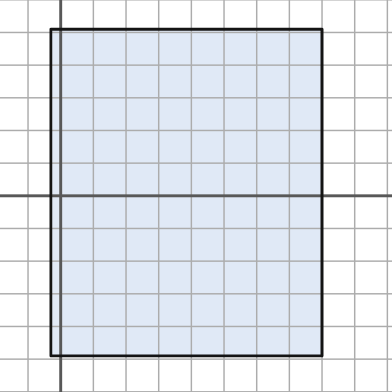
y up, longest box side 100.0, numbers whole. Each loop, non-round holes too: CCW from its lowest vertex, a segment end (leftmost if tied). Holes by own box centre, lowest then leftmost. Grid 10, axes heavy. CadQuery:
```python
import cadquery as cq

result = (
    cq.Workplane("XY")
    .moveTo(-3.0, -49.0)
    .lineTo(80.0, -49.0)
    .lineTo(80.0, 51.0)
    .lineTo(-3.0, 51.0)
    .close()
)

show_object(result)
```